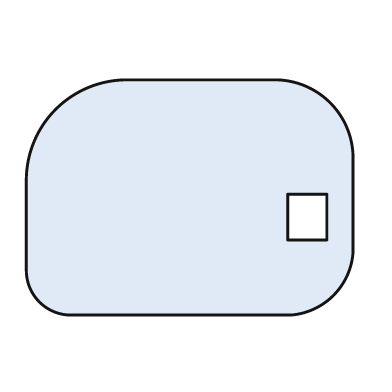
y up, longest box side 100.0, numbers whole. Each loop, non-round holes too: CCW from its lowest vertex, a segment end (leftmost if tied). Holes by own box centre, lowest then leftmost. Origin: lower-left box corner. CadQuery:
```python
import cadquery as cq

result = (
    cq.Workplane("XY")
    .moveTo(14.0, 0.0)
    .lineTo(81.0, 0.0)
    .threePointArc((94.0, 6.0), (100.0, 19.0))
    .lineTo(100.0, 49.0)
    .threePointArc((93.0, 65.0), (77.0, 72.0))
    .lineTo(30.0, 72.0)
    .threePointArc((9.0, 63.0), (0.0, 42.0))
    .lineTo(0.0, 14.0)
    .threePointArc((4.0, 4.0), (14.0, 0.0))
    .close()
    .moveTo(80.0, 23.0)
    .lineTo(92.0, 23.0)
    .lineTo(92.0, 37.0)
    .lineTo(80.0, 37.0)
    .close()
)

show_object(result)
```